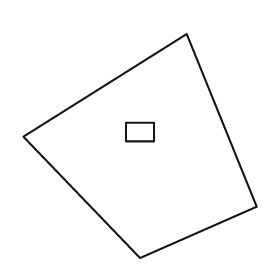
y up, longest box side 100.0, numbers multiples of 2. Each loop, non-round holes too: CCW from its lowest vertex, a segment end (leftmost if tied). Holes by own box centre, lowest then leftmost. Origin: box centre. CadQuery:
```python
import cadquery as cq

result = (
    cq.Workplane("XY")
    .moveTo(0.0, -48.0)
    .lineTo(50.0, -26.0)
    .lineTo(20.0, 48.0)
    .lineTo(-50.0, 4.0)
    .close()
    .moveTo(-6.0, 2.0)
    .lineTo(6.0, 2.0)
    .lineTo(6.0, 10.0)
    .lineTo(-6.0, 10.0)
    .close()
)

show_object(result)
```